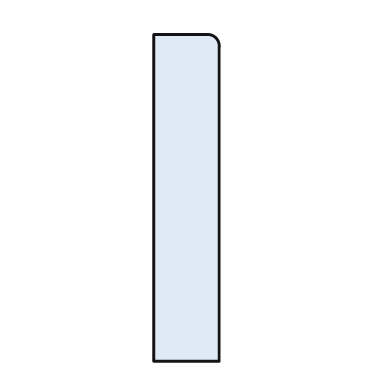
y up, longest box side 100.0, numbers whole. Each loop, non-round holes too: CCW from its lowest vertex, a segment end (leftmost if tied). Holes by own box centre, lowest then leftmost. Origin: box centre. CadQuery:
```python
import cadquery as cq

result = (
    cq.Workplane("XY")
    .moveTo(-10.0, -50.0)
    .lineTo(10.0, -50.0)
    .lineTo(10.0, 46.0)
    .threePointArc((9.0, 49.0), (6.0, 50.0))
    .lineTo(-10.0, 50.0)
    .close()
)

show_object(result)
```